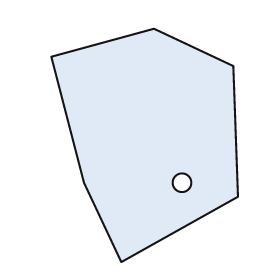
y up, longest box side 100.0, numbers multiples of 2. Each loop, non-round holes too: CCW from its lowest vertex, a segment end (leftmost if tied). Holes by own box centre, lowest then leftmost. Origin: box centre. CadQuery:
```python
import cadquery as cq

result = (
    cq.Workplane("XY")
    .moveTo(-10.0, -50.0)
    .lineTo(40.0, -22.0)
    .lineTo(38.0, 34.0)
    .lineTo(4.0, 50.0)
    .lineTo(-40.0, 38.0)
    .lineTo(-26.0, -16.0)
    .close()
    .moveTo(16.0, -16.0)
    .circle(4.0)
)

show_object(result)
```